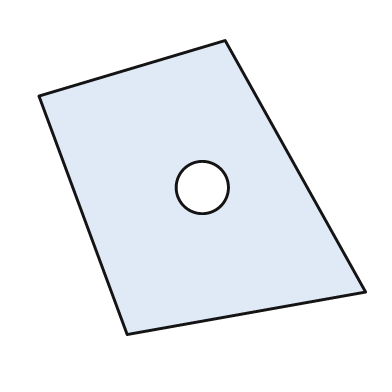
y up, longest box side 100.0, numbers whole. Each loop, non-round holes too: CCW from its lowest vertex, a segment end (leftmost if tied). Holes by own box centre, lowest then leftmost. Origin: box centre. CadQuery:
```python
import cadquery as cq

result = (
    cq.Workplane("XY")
    .moveTo(-23.0, -45.0)
    .lineTo(50.0, -32.0)
    .lineTo(7.0, 45.0)
    .lineTo(-50.0, 28.0)
    .close()
    .moveTo(0.0, 0.0)
    .circle(8.0)
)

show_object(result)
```